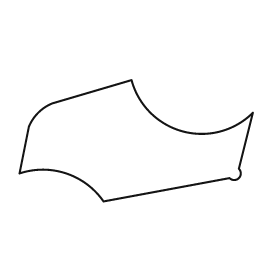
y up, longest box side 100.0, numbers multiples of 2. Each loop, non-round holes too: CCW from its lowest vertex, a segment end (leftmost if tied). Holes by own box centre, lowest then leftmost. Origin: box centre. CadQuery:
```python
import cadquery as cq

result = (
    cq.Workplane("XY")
    .moveTo(-14.0, -26.0)
    .lineTo(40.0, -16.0)
    .threePointArc((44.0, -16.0), (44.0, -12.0))
    .lineTo(50.0, 12.0)
    .threePointArc((20.0, 4.0), (-2.0, 26.0))
    .lineTo(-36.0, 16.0)
    .threePointArc((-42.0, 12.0), (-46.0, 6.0))
    .lineTo(-50.0, -14.0)
    .threePointArc((-30.0, -14.0), (-14.0, -26.0))
    .close()
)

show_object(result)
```